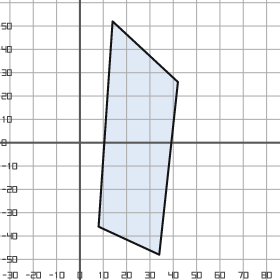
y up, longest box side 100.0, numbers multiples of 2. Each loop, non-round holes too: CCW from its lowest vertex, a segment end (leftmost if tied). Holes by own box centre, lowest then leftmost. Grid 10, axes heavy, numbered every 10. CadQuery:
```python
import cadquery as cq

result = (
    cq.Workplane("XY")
    .moveTo(34.0, -48.0)
    .lineTo(42.0, 26.0)
    .lineTo(14.0, 52.0)
    .lineTo(8.0, -36.0)
    .close()
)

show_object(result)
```